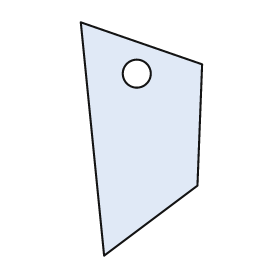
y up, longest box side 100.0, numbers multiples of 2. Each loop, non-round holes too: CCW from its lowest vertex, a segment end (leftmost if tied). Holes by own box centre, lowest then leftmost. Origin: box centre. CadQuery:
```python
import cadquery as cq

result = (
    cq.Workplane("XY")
    .moveTo(-16.0, -50.0)
    .lineTo(24.0, -20.0)
    .lineTo(26.0, 32.0)
    .lineTo(-26.0, 50.0)
    .close()
    .moveTo(-2.0, 28.0)
    .circle(6.0)
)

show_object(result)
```